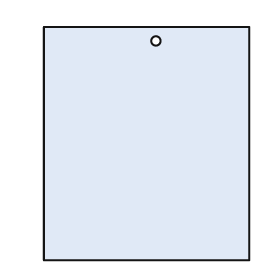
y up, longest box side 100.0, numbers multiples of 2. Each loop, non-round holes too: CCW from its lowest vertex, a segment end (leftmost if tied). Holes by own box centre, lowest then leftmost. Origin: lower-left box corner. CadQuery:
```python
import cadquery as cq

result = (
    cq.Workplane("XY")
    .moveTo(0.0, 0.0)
    .lineTo(88.0, 0.0)
    .lineTo(88.0, 100.0)
    .lineTo(0.0, 100.0)
    .close()
    .moveTo(48.0, 94.0)
    .circle(2.0)
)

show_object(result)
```